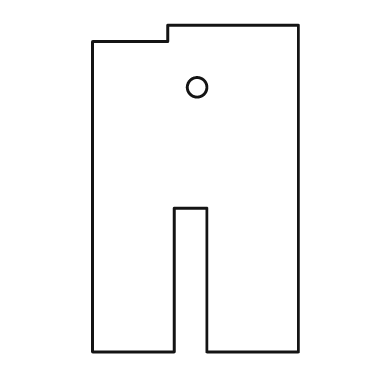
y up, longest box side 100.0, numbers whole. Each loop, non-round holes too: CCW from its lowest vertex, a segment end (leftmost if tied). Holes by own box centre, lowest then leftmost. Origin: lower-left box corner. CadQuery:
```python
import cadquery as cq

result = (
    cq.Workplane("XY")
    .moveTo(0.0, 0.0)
    .lineTo(25.0, 0.0)
    .lineTo(25.0, 44.0)
    .lineTo(35.0, 44.0)
    .lineTo(35.0, 0.0)
    .lineTo(63.0, 0.0)
    .lineTo(63.0, 100.0)
    .lineTo(23.0, 100.0)
    .lineTo(23.0, 95.0)
    .lineTo(0.0, 95.0)
    .close()
    .moveTo(32.0, 81.0)
    .circle(3.0)
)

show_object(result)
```